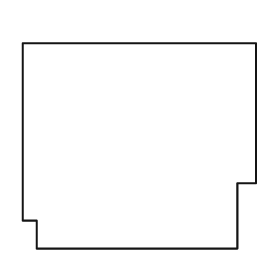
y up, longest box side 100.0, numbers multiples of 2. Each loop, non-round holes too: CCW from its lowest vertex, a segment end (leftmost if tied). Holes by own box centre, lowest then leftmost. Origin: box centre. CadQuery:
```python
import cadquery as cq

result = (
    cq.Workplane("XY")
    .moveTo(-44.0, -44.0)
    .lineTo(42.0, -44.0)
    .lineTo(42.0, -16.0)
    .lineTo(50.0, -16.0)
    .lineTo(50.0, 44.0)
    .lineTo(-50.0, 44.0)
    .lineTo(-50.0, -32.0)
    .lineTo(-44.0, -32.0)
    .close()
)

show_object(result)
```